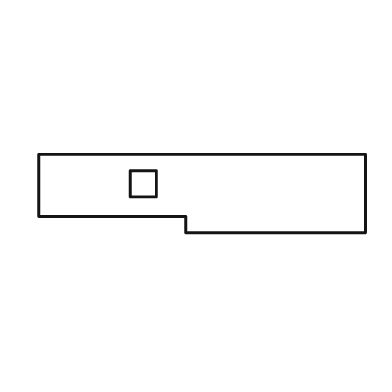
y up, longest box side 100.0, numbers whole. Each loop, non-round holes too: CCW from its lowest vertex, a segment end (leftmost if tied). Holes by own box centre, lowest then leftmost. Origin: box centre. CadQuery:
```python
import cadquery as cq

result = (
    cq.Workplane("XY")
    .moveTo(-5.0, -12.0)
    .lineTo(50.0, -12.0)
    .lineTo(50.0, 12.0)
    .lineTo(-50.0, 12.0)
    .lineTo(-50.0, -7.0)
    .lineTo(-5.0, -7.0)
    .close()
    .moveTo(-22.0, -1.0)
    .lineTo(-14.0, -1.0)
    .lineTo(-14.0, 7.0)
    .lineTo(-22.0, 7.0)
    .close()
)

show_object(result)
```